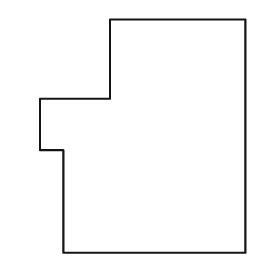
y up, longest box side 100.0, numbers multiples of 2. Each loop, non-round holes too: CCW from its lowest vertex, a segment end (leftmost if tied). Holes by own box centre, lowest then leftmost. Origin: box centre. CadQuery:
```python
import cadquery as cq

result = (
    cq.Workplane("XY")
    .moveTo(-34.0, -50.0)
    .lineTo(44.0, -50.0)
    .lineTo(44.0, 50.0)
    .lineTo(-14.0, 50.0)
    .lineTo(-14.0, 16.0)
    .lineTo(-44.0, 16.0)
    .lineTo(-44.0, -6.0)
    .lineTo(-34.0, -6.0)
    .close()
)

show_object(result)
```